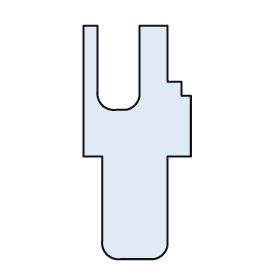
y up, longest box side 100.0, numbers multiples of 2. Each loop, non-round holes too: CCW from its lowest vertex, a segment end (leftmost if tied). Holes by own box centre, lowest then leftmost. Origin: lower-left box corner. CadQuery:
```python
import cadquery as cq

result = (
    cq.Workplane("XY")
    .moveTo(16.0, 0.0)
    .lineTo(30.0, 0.0)
    .threePointArc((34.0, 2.0), (36.0, 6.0))
    .lineTo(36.0, 44.0)
    .lineTo(46.0, 44.0)
    .lineTo(46.0, 70.0)
    .lineTo(42.0, 70.0)
    .lineTo(42.0, 76.0)
    .lineTo(36.0, 76.0)
    .lineTo(36.0, 100.0)
    .lineTo(24.0, 100.0)
    .lineTo(24.0, 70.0)
    .threePointArc((22.0, 66.0), (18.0, 64.0))
    .lineTo(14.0, 64.0)
    .threePointArc((8.0, 66.0), (6.0, 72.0))
    .lineTo(6.0, 100.0)
    .lineTo(0.0, 100.0)
    .lineTo(0.0, 44.0)
    .lineTo(8.0, 44.0)
    .lineTo(8.0, 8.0)
    .threePointArc((10.0, 2.0), (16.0, 0.0))
    .close()
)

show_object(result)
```